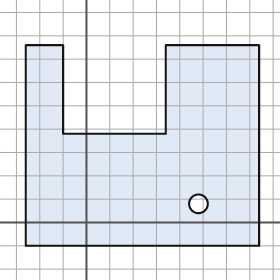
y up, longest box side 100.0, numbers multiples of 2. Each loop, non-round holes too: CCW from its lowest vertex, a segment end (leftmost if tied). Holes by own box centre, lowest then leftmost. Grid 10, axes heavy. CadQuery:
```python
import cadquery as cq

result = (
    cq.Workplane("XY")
    .moveTo(-26.0, -10.0)
    .lineTo(74.0, -10.0)
    .lineTo(74.0, 76.0)
    .lineTo(34.0, 76.0)
    .lineTo(34.0, 38.0)
    .lineTo(-10.0, 38.0)
    .lineTo(-10.0, 76.0)
    .lineTo(-26.0, 76.0)
    .close()
    .moveTo(48.0, 8.0)
    .circle(4.0)
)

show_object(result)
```